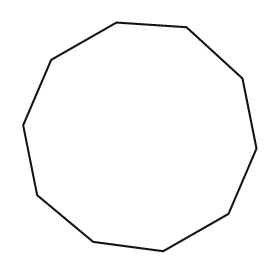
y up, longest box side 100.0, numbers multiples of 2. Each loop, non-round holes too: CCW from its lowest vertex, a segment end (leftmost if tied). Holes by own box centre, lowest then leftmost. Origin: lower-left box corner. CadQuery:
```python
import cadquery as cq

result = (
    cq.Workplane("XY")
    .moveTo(60.0, 0.0)
    .lineTo(88.0, 16.0)
    .lineTo(100.0, 44.0)
    .lineTo(94.0, 74.0)
    .lineTo(70.0, 96.0)
    .lineTo(40.0, 98.0)
    .lineTo(12.0, 82.0)
    .lineTo(0.0, 54.0)
    .lineTo(6.0, 24.0)
    .lineTo(30.0, 4.0)
    .close()
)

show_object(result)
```